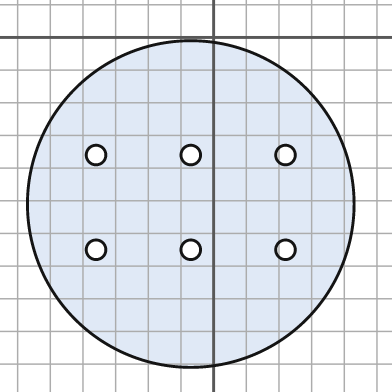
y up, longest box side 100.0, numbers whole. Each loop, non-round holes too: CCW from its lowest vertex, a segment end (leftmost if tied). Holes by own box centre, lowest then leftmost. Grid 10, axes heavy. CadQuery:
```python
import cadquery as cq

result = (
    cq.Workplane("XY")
    .moveTo(-7.0, -51.0)
    .circle(50.0)
    .moveTo(-36.0, -65.0)
    .circle(3.0)
    .moveTo(-7.0, -65.0)
    .circle(3.0)
    .moveTo(22.0, -65.0)
    .circle(3.0)
    .moveTo(-36.0, -36.0)
    .circle(3.0)
    .moveTo(-7.0, -36.0)
    .circle(3.0)
    .moveTo(22.0, -36.0)
    .circle(3.0)
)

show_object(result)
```